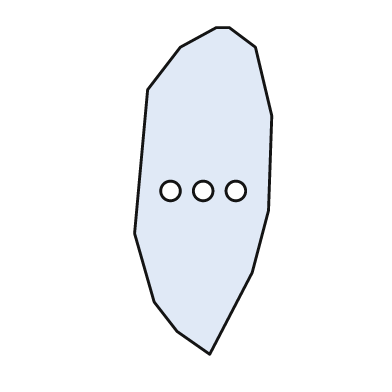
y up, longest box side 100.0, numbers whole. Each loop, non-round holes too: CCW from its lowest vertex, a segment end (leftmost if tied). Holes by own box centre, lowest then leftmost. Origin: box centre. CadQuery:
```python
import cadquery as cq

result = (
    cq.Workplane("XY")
    .moveTo(2.0, -50.0)
    .lineTo(15.0, -25.0)
    .lineTo(20.0, -6.0)
    .lineTo(21.0, 23.0)
    .lineTo(16.0, 44.0)
    .lineTo(8.0, 50.0)
    .lineTo(4.0, 50.0)
    .lineTo(-7.0, 44.0)
    .lineTo(-17.0, 31.0)
    .lineTo(-21.0, -13.0)
    .lineTo(-15.0, -34.0)
    .lineTo(-8.0, -43.0)
    .close()
    .moveTo(-10.0, 0.0)
    .circle(3.0)
    .moveTo(0.0, 0.0)
    .circle(3.0)
    .moveTo(10.0, 0.0)
    .circle(3.0)
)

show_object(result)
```